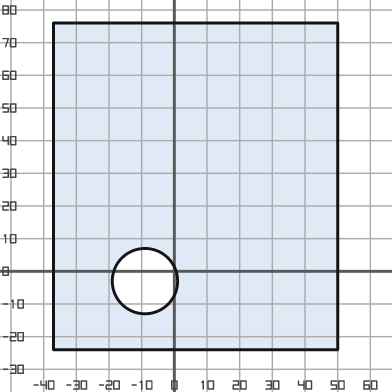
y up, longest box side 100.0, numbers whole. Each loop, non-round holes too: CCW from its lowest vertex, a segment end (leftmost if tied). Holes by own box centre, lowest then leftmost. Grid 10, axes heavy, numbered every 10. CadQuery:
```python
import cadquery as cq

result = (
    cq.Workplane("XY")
    .moveTo(-37.0, -24.0)
    .lineTo(50.0, -24.0)
    .lineTo(50.0, 76.0)
    .lineTo(-37.0, 76.0)
    .close()
    .moveTo(-9.0, -3.0)
    .circle(10.0)
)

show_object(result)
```